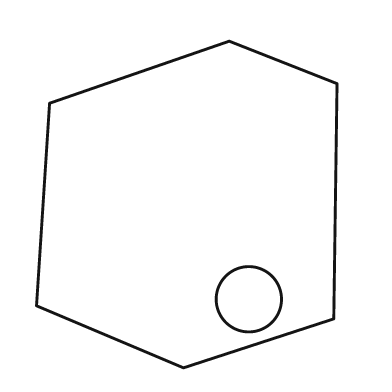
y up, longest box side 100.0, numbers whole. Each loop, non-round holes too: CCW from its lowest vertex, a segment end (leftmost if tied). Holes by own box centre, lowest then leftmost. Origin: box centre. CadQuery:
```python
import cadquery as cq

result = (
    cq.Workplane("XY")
    .moveTo(-1.0, -50.0)
    .lineTo(45.0, -35.0)
    .lineTo(46.0, 37.0)
    .lineTo(13.0, 50.0)
    .lineTo(-42.0, 31.0)
    .lineTo(-46.0, -31.0)
    .close()
    .moveTo(19.0, -29.0)
    .circle(10.0)
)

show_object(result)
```